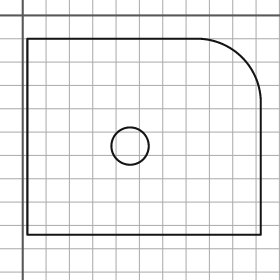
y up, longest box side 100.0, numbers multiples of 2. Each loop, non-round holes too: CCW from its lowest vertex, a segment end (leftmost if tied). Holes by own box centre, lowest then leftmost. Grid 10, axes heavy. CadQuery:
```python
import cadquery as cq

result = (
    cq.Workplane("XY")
    .moveTo(2.0, -94.0)
    .lineTo(102.0, -94.0)
    .lineTo(102.0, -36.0)
    .threePointArc((94.0, -18.0), (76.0, -10.0))
    .lineTo(2.0, -10.0)
    .close()
    .moveTo(46.0, -56.0)
    .circle(8.0)
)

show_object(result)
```